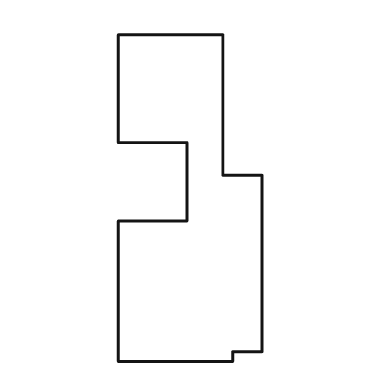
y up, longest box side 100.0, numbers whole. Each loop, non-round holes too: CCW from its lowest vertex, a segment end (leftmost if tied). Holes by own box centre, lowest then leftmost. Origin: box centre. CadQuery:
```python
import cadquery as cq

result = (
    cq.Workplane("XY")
    .moveTo(-22.0, -50.0)
    .lineTo(13.0, -50.0)
    .lineTo(13.0, -47.0)
    .lineTo(22.0, -47.0)
    .lineTo(22.0, 7.0)
    .lineTo(10.0, 7.0)
    .lineTo(10.0, 50.0)
    .lineTo(-22.0, 50.0)
    .lineTo(-22.0, 17.0)
    .lineTo(-1.0, 17.0)
    .lineTo(-1.0, -7.0)
    .lineTo(-22.0, -7.0)
    .close()
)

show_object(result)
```